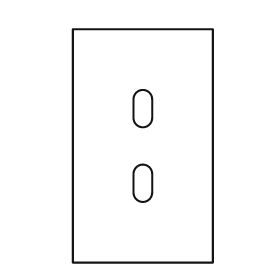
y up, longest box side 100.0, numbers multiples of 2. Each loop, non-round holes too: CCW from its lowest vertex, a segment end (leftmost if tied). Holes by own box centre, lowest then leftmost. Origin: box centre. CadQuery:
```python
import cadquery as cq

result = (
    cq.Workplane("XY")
    .moveTo(-30.0, -50.0)
    .lineTo(30.0, -50.0)
    .lineTo(30.0, 50.0)
    .lineTo(-30.0, 50.0)
    .close()
    .moveTo(-4.0, -20.0)
    .threePointArc((0.0, -24.0), (4.0, -20.0))
    .lineTo(4.0, -12.0)
    .threePointArc((0.0, -8.0), (-4.0, -12.0))
    .close()
    .moveTo(-4.0, 12.0)
    .threePointArc((0.0, 8.0), (4.0, 12.0))
    .lineTo(4.0, 20.0)
    .threePointArc((0.0, 24.0), (-4.0, 20.0))
    .close()
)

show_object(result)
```